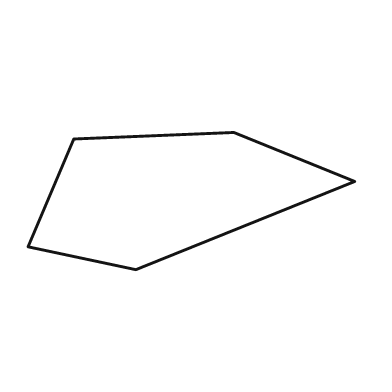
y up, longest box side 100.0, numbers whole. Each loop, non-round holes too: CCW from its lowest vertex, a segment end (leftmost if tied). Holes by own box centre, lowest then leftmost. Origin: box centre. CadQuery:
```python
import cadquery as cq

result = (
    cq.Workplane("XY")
    .moveTo(-17.0, -21.0)
    .lineTo(50.0, 6.0)
    .lineTo(13.0, 21.0)
    .lineTo(-36.0, 19.0)
    .lineTo(-50.0, -14.0)
    .close()
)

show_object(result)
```